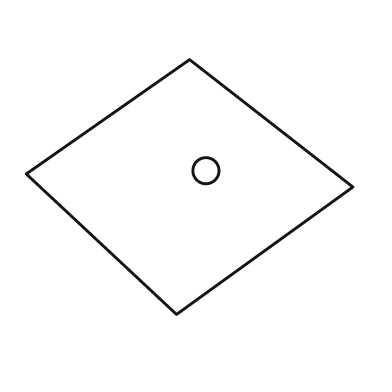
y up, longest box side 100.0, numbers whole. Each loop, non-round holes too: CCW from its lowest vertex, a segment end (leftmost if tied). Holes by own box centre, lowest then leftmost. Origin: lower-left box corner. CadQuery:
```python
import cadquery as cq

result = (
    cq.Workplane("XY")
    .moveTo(46.0, 0.0)
    .lineTo(100.0, 39.0)
    .lineTo(50.0, 78.0)
    .lineTo(0.0, 43.0)
    .close()
    .moveTo(55.0, 44.0)
    .circle(4.0)
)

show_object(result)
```